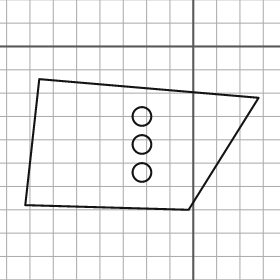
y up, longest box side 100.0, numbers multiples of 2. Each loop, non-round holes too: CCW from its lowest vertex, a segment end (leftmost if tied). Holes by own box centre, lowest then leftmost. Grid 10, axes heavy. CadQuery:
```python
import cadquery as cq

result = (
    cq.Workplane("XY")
    .moveTo(-2.0, -70.0)
    .lineTo(28.0, -22.0)
    .lineTo(-66.0, -14.0)
    .lineTo(-72.0, -68.0)
    .close()
    .moveTo(-22.0, -54.0)
    .circle(4.0)
    .moveTo(-22.0, -42.0)
    .circle(4.0)
    .moveTo(-22.0, -30.0)
    .circle(4.0)
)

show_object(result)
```